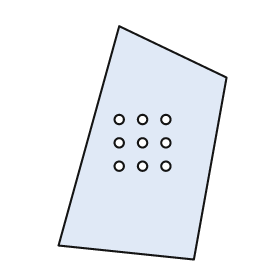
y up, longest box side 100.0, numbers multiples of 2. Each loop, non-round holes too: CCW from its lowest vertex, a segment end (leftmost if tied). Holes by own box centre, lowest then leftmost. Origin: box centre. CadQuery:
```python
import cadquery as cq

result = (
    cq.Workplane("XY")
    .moveTo(22.0, -50.0)
    .lineTo(36.0, 28.0)
    .lineTo(-10.0, 50.0)
    .lineTo(-36.0, -44.0)
    .close()
    .moveTo(-10.0, -10.0)
    .circle(2.0)
    .moveTo(0.0, -10.0)
    .circle(2.0)
    .moveTo(10.0, -10.0)
    .circle(2.0)
    .moveTo(-10.0, 0.0)
    .circle(2.0)
    .moveTo(0.0, 0.0)
    .circle(2.0)
    .moveTo(10.0, 0.0)
    .circle(2.0)
    .moveTo(-10.0, 10.0)
    .circle(2.0)
    .moveTo(0.0, 10.0)
    .circle(2.0)
    .moveTo(10.0, 10.0)
    .circle(2.0)
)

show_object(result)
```